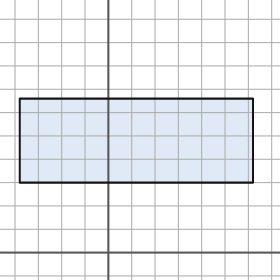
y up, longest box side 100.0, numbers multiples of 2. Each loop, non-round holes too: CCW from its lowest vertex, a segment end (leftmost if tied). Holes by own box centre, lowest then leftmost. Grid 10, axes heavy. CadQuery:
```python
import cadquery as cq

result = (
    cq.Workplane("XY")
    .moveTo(-38.0, 30.0)
    .lineTo(62.0, 30.0)
    .lineTo(62.0, 66.0)
    .lineTo(-38.0, 66.0)
    .close()
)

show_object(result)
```